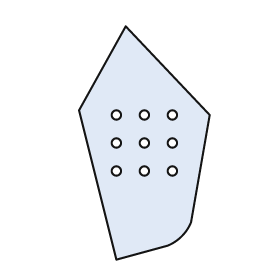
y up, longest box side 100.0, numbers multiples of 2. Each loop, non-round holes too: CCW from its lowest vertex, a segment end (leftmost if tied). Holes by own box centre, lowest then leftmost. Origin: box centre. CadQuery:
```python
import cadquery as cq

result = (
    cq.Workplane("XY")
    .moveTo(-12.0, -50.0)
    .lineTo(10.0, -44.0)
    .threePointArc((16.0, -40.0), (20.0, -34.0))
    .lineTo(28.0, 12.0)
    .lineTo(-8.0, 50.0)
    .lineTo(-28.0, 14.0)
    .close()
    .moveTo(-12.0, -12.0)
    .circle(2.0)
    .moveTo(0.0, -12.0)
    .circle(2.0)
    .moveTo(12.0, -12.0)
    .circle(2.0)
    .moveTo(-12.0, 0.0)
    .circle(2.0)
    .moveTo(0.0, 0.0)
    .circle(2.0)
    .moveTo(12.0, 0.0)
    .circle(2.0)
    .moveTo(-12.0, 12.0)
    .circle(2.0)
    .moveTo(0.0, 12.0)
    .circle(2.0)
    .moveTo(12.0, 12.0)
    .circle(2.0)
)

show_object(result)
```